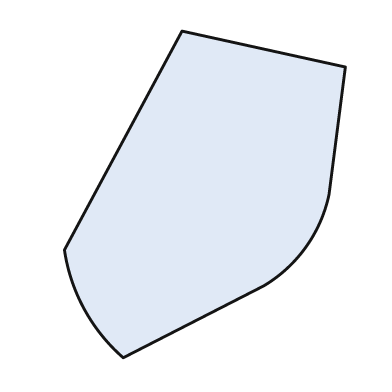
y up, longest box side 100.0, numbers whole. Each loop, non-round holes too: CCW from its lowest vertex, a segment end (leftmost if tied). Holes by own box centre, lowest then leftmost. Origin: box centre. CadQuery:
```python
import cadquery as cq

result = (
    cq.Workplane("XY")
    .moveTo(-25.0, -50.0)
    .lineTo(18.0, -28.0)
    .threePointArc((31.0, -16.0), (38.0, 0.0))
    .lineTo(43.0, 39.0)
    .lineTo(-7.0, 50.0)
    .lineTo(-43.0, -17.0)
    .threePointArc((-37.0, -35.0), (-25.0, -50.0))
    .close()
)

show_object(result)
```